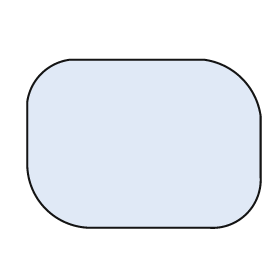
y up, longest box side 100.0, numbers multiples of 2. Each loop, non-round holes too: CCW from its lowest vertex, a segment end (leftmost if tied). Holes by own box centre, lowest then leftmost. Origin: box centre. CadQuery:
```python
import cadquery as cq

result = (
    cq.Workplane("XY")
    .moveTo(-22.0, -36.0)
    .lineTo(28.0, -36.0)
    .threePointArc((44.0, -30.0), (50.0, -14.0))
    .lineTo(50.0, 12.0)
    .threePointArc((42.0, 28.0), (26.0, 36.0))
    .lineTo(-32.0, 36.0)
    .threePointArc((-44.0, 30.0), (-50.0, 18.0))
    .lineTo(-50.0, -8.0)
    .threePointArc((-42.0, -28.0), (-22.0, -36.0))
    .close()
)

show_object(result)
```